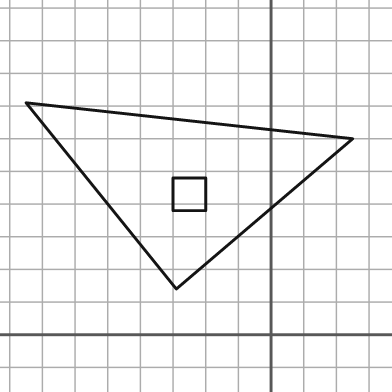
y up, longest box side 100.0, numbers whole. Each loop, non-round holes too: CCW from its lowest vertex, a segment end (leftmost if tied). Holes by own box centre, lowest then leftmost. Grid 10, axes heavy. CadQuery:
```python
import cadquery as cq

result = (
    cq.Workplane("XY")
    .moveTo(-29.0, 14.0)
    .lineTo(25.0, 60.0)
    .lineTo(-75.0, 71.0)
    .close()
    .moveTo(-30.0, 38.0)
    .lineTo(-20.0, 38.0)
    .lineTo(-20.0, 48.0)
    .lineTo(-30.0, 48.0)
    .close()
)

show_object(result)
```